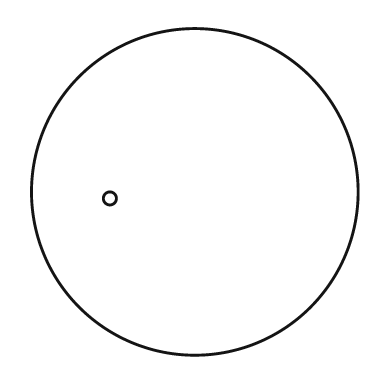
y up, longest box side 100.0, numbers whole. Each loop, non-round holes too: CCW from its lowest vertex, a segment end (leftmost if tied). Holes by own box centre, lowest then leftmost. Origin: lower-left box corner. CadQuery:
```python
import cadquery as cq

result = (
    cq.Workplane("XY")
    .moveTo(50.0, 50.0)
    .circle(50.0)
    .moveTo(24.0, 48.0)
    .circle(2.0)
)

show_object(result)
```